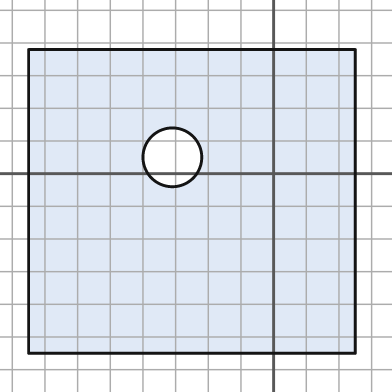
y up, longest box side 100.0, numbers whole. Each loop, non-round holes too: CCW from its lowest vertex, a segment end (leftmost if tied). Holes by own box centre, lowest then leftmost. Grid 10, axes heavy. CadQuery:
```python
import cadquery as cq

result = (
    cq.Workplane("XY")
    .moveTo(-75.0, -55.0)
    .lineTo(25.0, -55.0)
    .lineTo(25.0, 38.0)
    .lineTo(-75.0, 38.0)
    .close()
    .moveTo(-31.0, 5.0)
    .circle(9.0)
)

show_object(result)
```